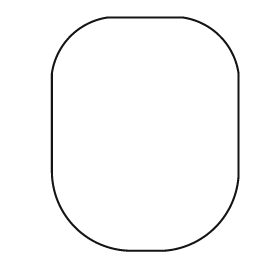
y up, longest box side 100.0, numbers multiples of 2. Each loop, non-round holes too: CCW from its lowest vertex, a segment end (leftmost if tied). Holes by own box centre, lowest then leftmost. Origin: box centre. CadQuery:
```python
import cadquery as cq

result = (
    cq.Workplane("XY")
    .moveTo(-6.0, -50.0)
    .lineTo(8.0, -50.0)
    .threePointArc((30.0, -40.0), (40.0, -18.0))
    .lineTo(40.0, 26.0)
    .threePointArc((32.0, 42.0), (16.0, 50.0))
    .lineTo(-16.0, 50.0)
    .threePointArc((-32.0, 42.0), (-40.0, 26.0))
    .lineTo(-40.0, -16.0)
    .threePointArc((-30.0, -40.0), (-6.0, -50.0))
    .close()
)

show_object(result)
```